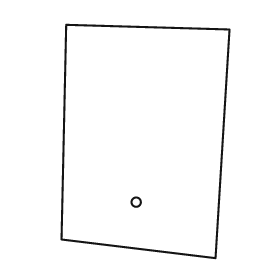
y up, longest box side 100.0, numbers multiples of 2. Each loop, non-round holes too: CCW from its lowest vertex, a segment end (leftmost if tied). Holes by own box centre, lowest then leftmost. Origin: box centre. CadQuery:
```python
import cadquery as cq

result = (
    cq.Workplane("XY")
    .moveTo(30.0, -50.0)
    .lineTo(36.0, 48.0)
    .lineTo(-34.0, 50.0)
    .lineTo(-36.0, -42.0)
    .close()
    .moveTo(-4.0, -26.0)
    .circle(2.0)
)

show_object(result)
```